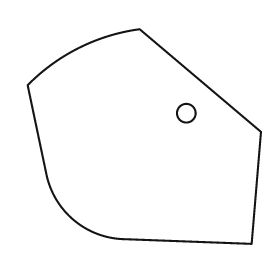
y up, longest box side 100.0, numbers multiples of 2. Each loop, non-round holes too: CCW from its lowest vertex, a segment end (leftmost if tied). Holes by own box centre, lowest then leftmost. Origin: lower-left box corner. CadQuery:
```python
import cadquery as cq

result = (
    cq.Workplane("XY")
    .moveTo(96.0, 0.0)
    .lineTo(100.0, 48.0)
    .lineTo(48.0, 92.0)
    .threePointArc((22.0, 84.0), (0.0, 68.0))
    .lineTo(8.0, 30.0)
    .threePointArc((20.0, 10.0), (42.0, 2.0))
    .close()
    .moveTo(68.0, 56.0)
    .circle(4.0)
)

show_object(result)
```